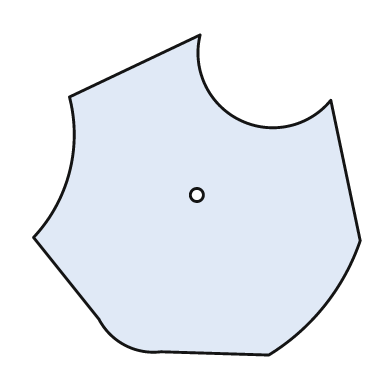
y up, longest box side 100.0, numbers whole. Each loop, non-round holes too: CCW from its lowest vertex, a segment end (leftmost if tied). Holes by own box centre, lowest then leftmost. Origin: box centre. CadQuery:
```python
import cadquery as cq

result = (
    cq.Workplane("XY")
    .moveTo(22.0, -49.0)
    .threePointArc((39.0, -34.0), (50.0, -14.0))
    .lineTo(41.0, 29.0)
    .threePointArc((13.0, 23.0), (1.0, 49.0))
    .lineTo(-39.0, 30.0)
    .threePointArc((-39.0, 7.0), (-50.0, -13.0))
    .lineTo(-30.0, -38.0)
    .threePointArc((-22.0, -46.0), (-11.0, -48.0))
    .close()
    .moveTo(0.0, 0.0)
    .circle(2.0)
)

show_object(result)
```